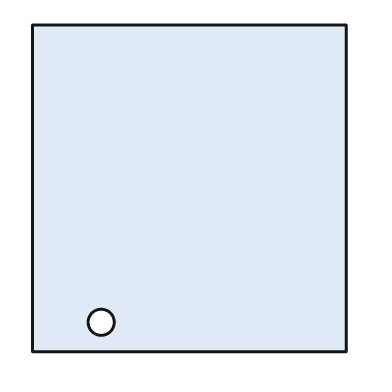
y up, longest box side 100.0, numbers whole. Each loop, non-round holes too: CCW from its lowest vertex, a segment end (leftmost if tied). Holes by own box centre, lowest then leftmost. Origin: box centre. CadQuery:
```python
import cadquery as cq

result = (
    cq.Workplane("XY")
    .moveTo(-48.0, -50.0)
    .lineTo(48.0, -50.0)
    .lineTo(48.0, 50.0)
    .lineTo(-48.0, 50.0)
    .close()
    .moveTo(-27.0, -41.0)
    .circle(4.0)
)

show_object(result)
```